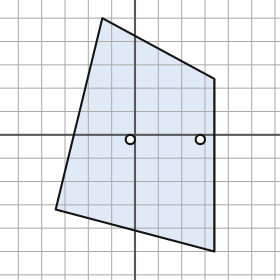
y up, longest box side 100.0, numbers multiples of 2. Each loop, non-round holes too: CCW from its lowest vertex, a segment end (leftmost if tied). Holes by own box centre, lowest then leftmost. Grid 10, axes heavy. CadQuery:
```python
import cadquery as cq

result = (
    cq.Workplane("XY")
    .moveTo(34.0, -50.0)
    .lineTo(34.0, 24.0)
    .lineTo(-14.0, 50.0)
    .lineTo(-34.0, -32.0)
    .close()
    .moveTo(-2.0, -2.0)
    .circle(2.0)
    .moveTo(28.0, -2.0)
    .circle(2.0)
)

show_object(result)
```